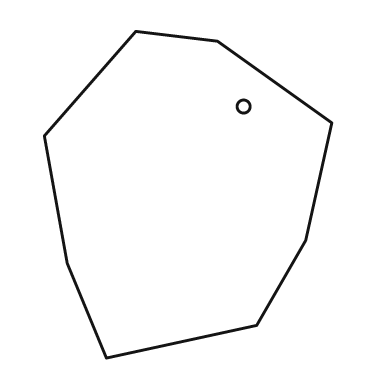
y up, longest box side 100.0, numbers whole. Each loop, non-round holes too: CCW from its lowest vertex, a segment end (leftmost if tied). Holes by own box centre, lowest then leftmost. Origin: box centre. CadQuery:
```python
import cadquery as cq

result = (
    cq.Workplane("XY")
    .moveTo(-25.0, -50.0)
    .lineTo(21.0, -40.0)
    .lineTo(36.0, -14.0)
    .lineTo(44.0, 22.0)
    .lineTo(9.0, 47.0)
    .lineTo(-16.0, 50.0)
    .lineTo(-44.0, 18.0)
    .lineTo(-37.0, -21.0)
    .close()
    .moveTo(17.0, 27.0)
    .circle(2.0)
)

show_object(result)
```